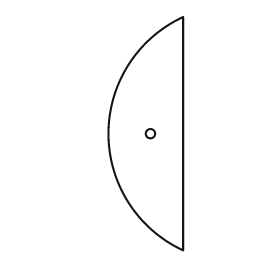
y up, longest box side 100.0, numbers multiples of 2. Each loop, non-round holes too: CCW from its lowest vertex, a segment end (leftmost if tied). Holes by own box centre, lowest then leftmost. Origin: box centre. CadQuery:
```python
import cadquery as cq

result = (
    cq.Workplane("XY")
    .moveTo(16.0, -50.0)
    .lineTo(16.0, 50.0)
    .threePointArc((-16.0, 0.0), (16.0, -50.0))
    .close()
    .moveTo(2.0, 0.0)
    .circle(2.0)
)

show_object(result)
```